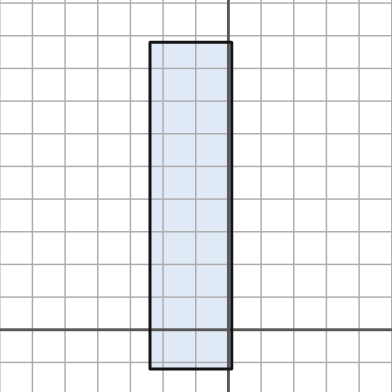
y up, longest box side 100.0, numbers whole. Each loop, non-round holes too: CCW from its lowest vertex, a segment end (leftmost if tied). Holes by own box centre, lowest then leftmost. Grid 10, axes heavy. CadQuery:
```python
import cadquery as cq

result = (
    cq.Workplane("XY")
    .moveTo(-24.0, -12.0)
    .lineTo(1.0, -12.0)
    .lineTo(1.0, 88.0)
    .lineTo(-24.0, 88.0)
    .close()
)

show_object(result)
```